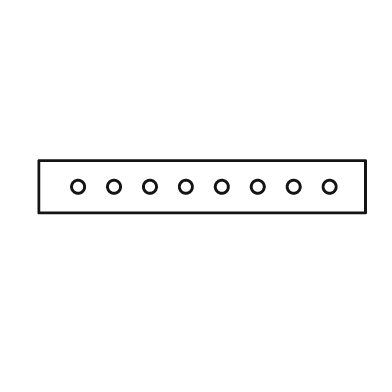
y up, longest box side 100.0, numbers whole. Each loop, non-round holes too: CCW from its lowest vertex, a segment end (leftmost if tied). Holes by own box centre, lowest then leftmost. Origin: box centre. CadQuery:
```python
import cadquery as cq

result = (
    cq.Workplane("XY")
    .moveTo(-50.0, -8.0)
    .lineTo(50.0, -8.0)
    .lineTo(50.0, 8.0)
    .lineTo(-50.0, 8.0)
    .close()
    .moveTo(-38.0, 0.0)
    .circle(2.0)
    .moveTo(-27.0, 0.0)
    .circle(2.0)
    .moveTo(-16.0, 0.0)
    .circle(2.0)
    .moveTo(-5.0, 0.0)
    .circle(2.0)
    .moveTo(6.0, 0.0)
    .circle(2.0)
    .moveTo(17.0, 0.0)
    .circle(2.0)
    .moveTo(28.0, 0.0)
    .circle(2.0)
    .moveTo(39.0, 0.0)
    .circle(2.0)
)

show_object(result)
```